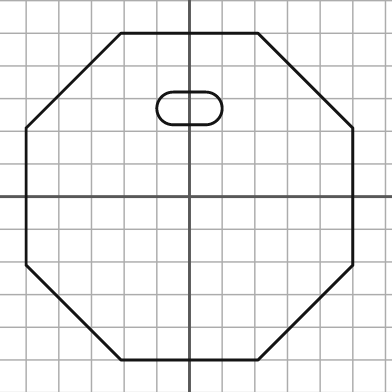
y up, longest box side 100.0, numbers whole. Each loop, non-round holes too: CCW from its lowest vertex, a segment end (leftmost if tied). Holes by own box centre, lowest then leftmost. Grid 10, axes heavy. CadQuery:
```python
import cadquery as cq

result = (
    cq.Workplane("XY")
    .moveTo(-21.0, -50.0)
    .lineTo(21.0, -50.0)
    .lineTo(50.0, -21.0)
    .lineTo(50.0, 21.0)
    .lineTo(21.0, 50.0)
    .lineTo(-21.0, 50.0)
    .lineTo(-50.0, 21.0)
    .lineTo(-50.0, -21.0)
    .close()
    .moveTo(-5.0, 22.0)
    .lineTo(5.0, 22.0)
    .threePointArc((10.0, 27.0), (5.0, 32.0))
    .lineTo(-5.0, 32.0)
    .threePointArc((-10.0, 27.0), (-5.0, 22.0))
    .close()
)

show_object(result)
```